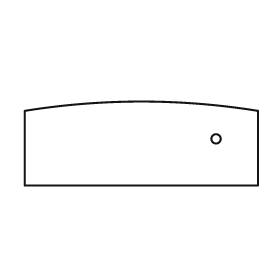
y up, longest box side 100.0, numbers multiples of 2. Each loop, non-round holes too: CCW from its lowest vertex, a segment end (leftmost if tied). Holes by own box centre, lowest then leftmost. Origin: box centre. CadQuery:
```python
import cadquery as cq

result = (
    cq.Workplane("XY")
    .moveTo(-50.0, -18.0)
    .lineTo(50.0, -18.0)
    .lineTo(50.0, 14.0)
    .threePointArc((0.0, 18.0), (-50.0, 14.0))
    .close()
    .moveTo(32.0, 2.0)
    .circle(2.0)
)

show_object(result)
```